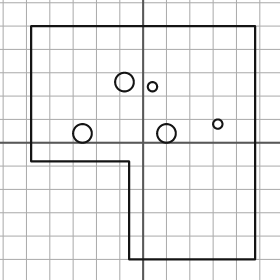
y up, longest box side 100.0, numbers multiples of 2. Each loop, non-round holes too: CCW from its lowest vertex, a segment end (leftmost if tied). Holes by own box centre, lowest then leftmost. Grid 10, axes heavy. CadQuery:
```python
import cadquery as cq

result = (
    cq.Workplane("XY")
    .moveTo(-6.0, -50.0)
    .lineTo(48.0, -50.0)
    .lineTo(48.0, 50.0)
    .lineTo(-48.0, 50.0)
    .lineTo(-48.0, -8.0)
    .lineTo(-6.0, -8.0)
    .close()
    .moveTo(-26.0, 4.0)
    .circle(4.0)
    .moveTo(10.0, 4.0)
    .circle(4.0)
    .moveTo(32.0, 8.0)
    .circle(2.0)
    .moveTo(4.0, 24.0)
    .circle(2.0)
    .moveTo(-8.0, 26.0)
    .circle(4.0)
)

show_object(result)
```